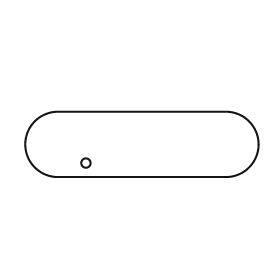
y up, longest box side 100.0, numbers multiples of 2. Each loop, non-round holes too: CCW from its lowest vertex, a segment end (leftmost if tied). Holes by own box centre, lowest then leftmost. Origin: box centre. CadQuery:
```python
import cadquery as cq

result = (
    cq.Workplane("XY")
    .moveTo(-36.0, -14.0)
    .lineTo(36.0, -14.0)
    .threePointArc((50.0, 0.0), (36.0, 14.0))
    .lineTo(-36.0, 14.0)
    .threePointArc((-50.0, 0.0), (-36.0, -14.0))
    .close()
    .moveTo(-24.0, -8.0)
    .circle(2.0)
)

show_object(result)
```